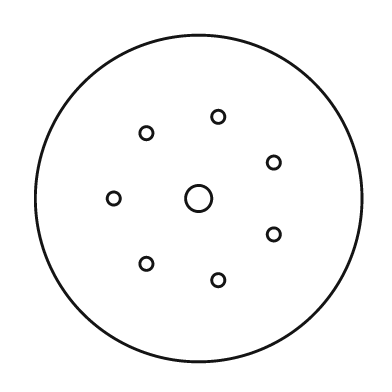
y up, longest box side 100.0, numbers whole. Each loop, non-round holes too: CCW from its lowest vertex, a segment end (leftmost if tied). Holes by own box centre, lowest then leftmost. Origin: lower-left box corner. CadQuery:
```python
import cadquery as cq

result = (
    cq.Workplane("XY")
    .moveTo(50.0, 50.0)
    .circle(50.0)
    .moveTo(56.0, 25.0)
    .circle(2.0)
    .moveTo(34.0, 30.0)
    .circle(2.0)
    .moveTo(73.0, 39.0)
    .circle(2.0)
    .moveTo(24.0, 50.0)
    .circle(2.0)
    .moveTo(50.0, 50.0)
    .circle(4.0)
    .moveTo(73.0, 61.0)
    .circle(2.0)
    .moveTo(34.0, 70.0)
    .circle(2.0)
    .moveTo(56.0, 75.0)
    .circle(2.0)
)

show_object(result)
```